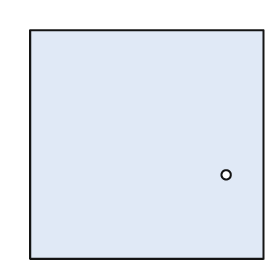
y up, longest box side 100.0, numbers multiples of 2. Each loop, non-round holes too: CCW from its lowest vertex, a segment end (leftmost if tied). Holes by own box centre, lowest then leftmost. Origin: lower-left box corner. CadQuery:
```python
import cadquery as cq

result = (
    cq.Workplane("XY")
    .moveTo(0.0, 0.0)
    .lineTo(100.0, 0.0)
    .lineTo(100.0, 98.0)
    .lineTo(0.0, 98.0)
    .close()
    .moveTo(84.0, 36.0)
    .circle(2.0)
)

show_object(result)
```